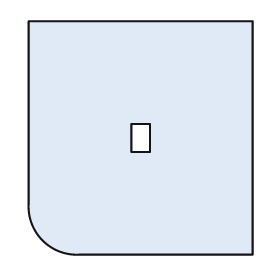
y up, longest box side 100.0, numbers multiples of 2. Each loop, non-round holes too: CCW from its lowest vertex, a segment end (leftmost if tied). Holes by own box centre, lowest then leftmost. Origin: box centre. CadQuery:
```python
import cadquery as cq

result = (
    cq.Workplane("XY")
    .moveTo(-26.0, -50.0)
    .lineTo(48.0, -50.0)
    .lineTo(48.0, 50.0)
    .lineTo(-48.0, 50.0)
    .lineTo(-48.0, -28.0)
    .threePointArc((-42.0, -44.0), (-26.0, -50.0))
    .close()
    .moveTo(-4.0, -6.0)
    .lineTo(4.0, -6.0)
    .lineTo(4.0, 6.0)
    .lineTo(-4.0, 6.0)
    .close()
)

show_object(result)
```